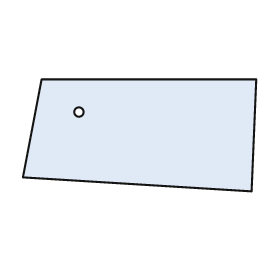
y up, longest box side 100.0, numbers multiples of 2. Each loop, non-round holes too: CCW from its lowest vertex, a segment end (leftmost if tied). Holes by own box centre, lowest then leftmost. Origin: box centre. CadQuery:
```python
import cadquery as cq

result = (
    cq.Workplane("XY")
    .moveTo(48.0, -24.0)
    .lineTo(50.0, 24.0)
    .lineTo(-42.0, 24.0)
    .lineTo(-50.0, -18.0)
    .close()
    .moveTo(-26.0, 10.0)
    .circle(2.0)
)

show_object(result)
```